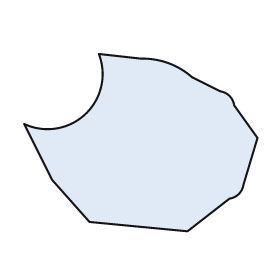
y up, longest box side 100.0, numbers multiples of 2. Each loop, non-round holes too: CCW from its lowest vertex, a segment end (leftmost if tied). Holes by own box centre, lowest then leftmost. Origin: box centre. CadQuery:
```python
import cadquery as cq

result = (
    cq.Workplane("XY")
    .moveTo(20.0, -38.0)
    .lineTo(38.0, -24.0)
    .threePointArc((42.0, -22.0), (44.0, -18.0))
    .lineTo(50.0, 2.0)
    .lineTo(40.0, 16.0)
    .threePointArc((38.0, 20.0), (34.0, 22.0))
    .lineTo(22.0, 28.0)
    .threePointArc((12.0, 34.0), (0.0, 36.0))
    .lineTo(-18.0, 38.0)
    .threePointArc((-24.0, 12.0), (-50.0, 8.0))
    .lineTo(-38.0, -16.0)
    .lineTo(-22.0, -34.0)
    .close()
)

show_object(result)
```